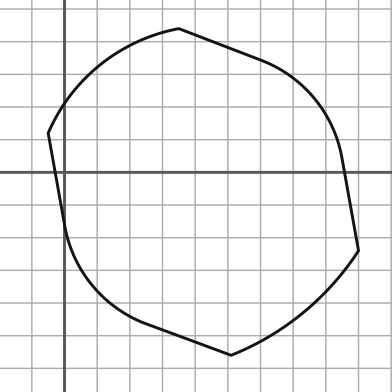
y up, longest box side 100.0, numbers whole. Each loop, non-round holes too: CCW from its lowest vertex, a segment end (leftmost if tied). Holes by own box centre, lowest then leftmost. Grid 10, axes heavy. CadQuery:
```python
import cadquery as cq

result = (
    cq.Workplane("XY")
    .moveTo(51.0, -56.0)
    .threePointArc((73.0, -43.0), (90.0, -24.0))
    .lineTo(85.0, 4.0)
    .threePointArc((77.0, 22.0), (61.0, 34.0))
    .lineTo(35.0, 44.0)
    .threePointArc((11.0, 33.0), (-5.0, 12.0))
    .lineTo(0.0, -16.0)
    .threePointArc((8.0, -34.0), (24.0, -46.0))
    .close()
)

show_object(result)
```